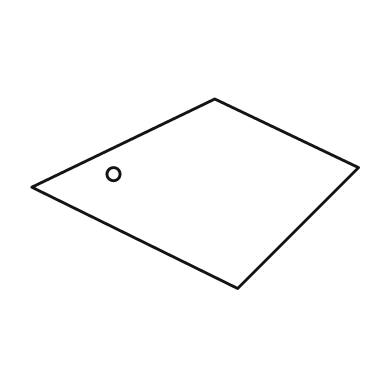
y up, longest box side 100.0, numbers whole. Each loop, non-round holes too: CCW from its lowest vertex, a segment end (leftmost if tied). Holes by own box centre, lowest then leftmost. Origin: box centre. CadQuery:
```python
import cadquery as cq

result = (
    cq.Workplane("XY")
    .moveTo(13.0, -29.0)
    .lineTo(50.0, 8.0)
    .lineTo(6.0, 29.0)
    .lineTo(-50.0, 2.0)
    .close()
    .moveTo(-25.0, 6.0)
    .circle(2.0)
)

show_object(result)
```